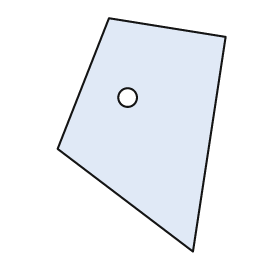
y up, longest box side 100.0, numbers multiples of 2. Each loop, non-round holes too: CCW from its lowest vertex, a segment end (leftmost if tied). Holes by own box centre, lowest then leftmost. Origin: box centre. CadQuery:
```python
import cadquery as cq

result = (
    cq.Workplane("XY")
    .moveTo(22.0, -50.0)
    .lineTo(36.0, 42.0)
    .lineTo(-14.0, 50.0)
    .lineTo(-36.0, -6.0)
    .close()
    .moveTo(-6.0, 16.0)
    .circle(4.0)
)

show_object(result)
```